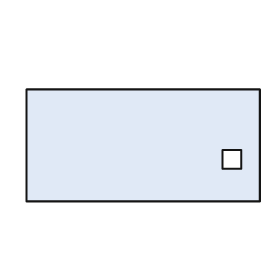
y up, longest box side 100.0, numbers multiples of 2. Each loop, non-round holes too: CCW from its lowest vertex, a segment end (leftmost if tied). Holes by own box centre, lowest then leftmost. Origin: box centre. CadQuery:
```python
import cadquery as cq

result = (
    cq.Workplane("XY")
    .moveTo(-50.0, -24.0)
    .lineTo(50.0, -24.0)
    .lineTo(50.0, 24.0)
    .lineTo(-50.0, 24.0)
    .close()
    .moveTo(34.0, -10.0)
    .lineTo(42.0, -10.0)
    .lineTo(42.0, -2.0)
    .lineTo(34.0, -2.0)
    .close()
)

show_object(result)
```